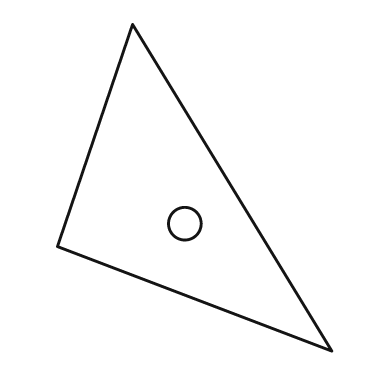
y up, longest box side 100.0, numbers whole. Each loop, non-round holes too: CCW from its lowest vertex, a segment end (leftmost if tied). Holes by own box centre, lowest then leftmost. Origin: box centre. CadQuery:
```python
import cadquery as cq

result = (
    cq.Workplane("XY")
    .moveTo(42.0, -50.0)
    .lineTo(-19.0, 50.0)
    .lineTo(-42.0, -18.0)
    .close()
    .moveTo(-3.0, -11.0)
    .circle(5.0)
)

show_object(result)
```